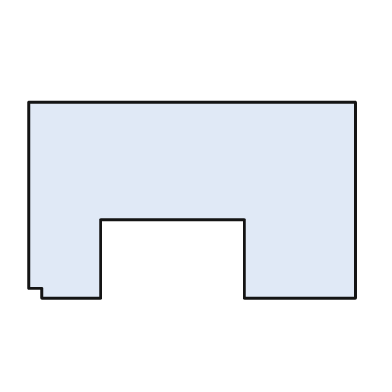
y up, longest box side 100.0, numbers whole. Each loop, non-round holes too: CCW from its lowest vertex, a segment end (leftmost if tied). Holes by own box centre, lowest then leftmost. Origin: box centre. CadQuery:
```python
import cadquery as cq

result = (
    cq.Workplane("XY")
    .moveTo(-46.0, -30.0)
    .lineTo(-28.0, -30.0)
    .lineTo(-28.0, -6.0)
    .lineTo(16.0, -6.0)
    .lineTo(16.0, -30.0)
    .lineTo(50.0, -30.0)
    .lineTo(50.0, 30.0)
    .lineTo(-50.0, 30.0)
    .lineTo(-50.0, -27.0)
    .lineTo(-46.0, -27.0)
    .close()
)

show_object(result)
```